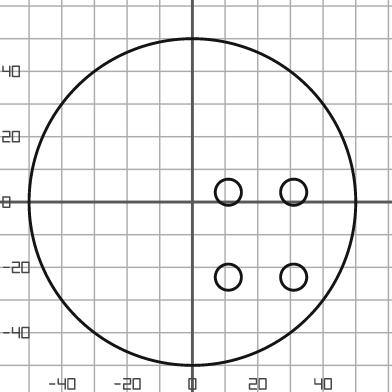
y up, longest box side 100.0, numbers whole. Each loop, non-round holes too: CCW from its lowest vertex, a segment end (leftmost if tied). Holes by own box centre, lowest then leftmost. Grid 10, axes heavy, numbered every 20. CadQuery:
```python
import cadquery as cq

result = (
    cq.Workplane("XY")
    .moveTo(0.0, 0.0)
    .circle(50.0)
    .moveTo(11.0, -23.0)
    .circle(4.0)
    .moveTo(31.0, -23.0)
    .circle(4.0)
    .moveTo(11.0, 3.0)
    .circle(4.0)
    .moveTo(31.0, 3.0)
    .circle(4.0)
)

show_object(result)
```